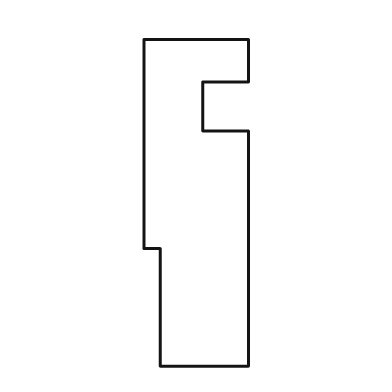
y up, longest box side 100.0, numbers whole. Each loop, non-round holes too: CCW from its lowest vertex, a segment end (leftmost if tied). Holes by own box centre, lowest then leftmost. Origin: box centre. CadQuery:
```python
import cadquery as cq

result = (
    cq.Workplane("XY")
    .moveTo(-11.0, -50.0)
    .lineTo(16.0, -50.0)
    .lineTo(16.0, 22.0)
    .lineTo(2.0, 22.0)
    .lineTo(2.0, 37.0)
    .lineTo(16.0, 37.0)
    .lineTo(16.0, 50.0)
    .lineTo(-16.0, 50.0)
    .lineTo(-16.0, -14.0)
    .lineTo(-11.0, -14.0)
    .close()
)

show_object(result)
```